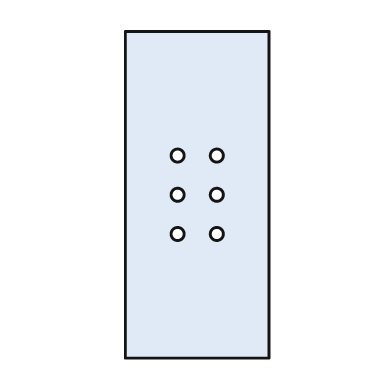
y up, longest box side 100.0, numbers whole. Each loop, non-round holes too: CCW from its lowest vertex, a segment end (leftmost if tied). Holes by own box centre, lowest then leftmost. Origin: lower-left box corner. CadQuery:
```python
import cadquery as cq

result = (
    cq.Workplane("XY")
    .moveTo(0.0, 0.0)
    .lineTo(44.0, 0.0)
    .lineTo(44.0, 100.0)
    .lineTo(0.0, 100.0)
    .close()
    .moveTo(16.0, 38.0)
    .circle(2.0)
    .moveTo(28.0, 38.0)
    .circle(2.0)
    .moveTo(16.0, 50.0)
    .circle(2.0)
    .moveTo(28.0, 50.0)
    .circle(2.0)
    .moveTo(16.0, 62.0)
    .circle(2.0)
    .moveTo(28.0, 62.0)
    .circle(2.0)
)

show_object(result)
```